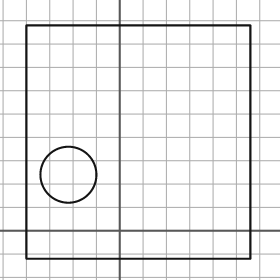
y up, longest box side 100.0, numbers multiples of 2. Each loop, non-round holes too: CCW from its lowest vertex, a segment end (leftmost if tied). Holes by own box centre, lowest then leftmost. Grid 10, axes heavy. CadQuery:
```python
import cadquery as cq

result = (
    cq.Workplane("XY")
    .moveTo(-40.0, -12.0)
    .lineTo(56.0, -12.0)
    .lineTo(56.0, 88.0)
    .lineTo(-40.0, 88.0)
    .close()
    .moveTo(-22.0, 24.0)
    .circle(12.0)
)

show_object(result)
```